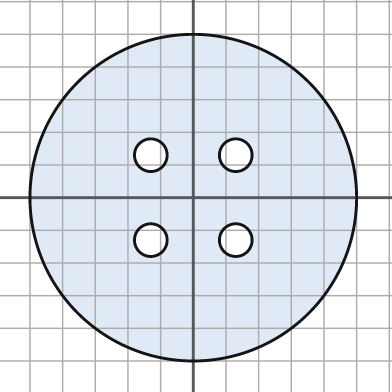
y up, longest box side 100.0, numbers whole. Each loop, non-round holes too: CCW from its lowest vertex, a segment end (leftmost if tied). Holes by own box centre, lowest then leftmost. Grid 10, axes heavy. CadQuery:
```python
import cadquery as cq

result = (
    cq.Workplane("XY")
    .moveTo(0.0, 0.0)
    .circle(50.0)
    .moveTo(-13.0, -13.0)
    .circle(5.0)
    .moveTo(13.0, -13.0)
    .circle(5.0)
    .moveTo(-13.0, 13.0)
    .circle(5.0)
    .moveTo(13.0, 13.0)
    .circle(5.0)
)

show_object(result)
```